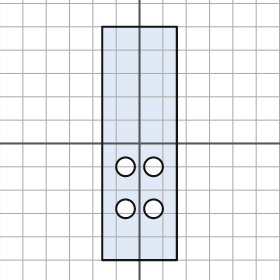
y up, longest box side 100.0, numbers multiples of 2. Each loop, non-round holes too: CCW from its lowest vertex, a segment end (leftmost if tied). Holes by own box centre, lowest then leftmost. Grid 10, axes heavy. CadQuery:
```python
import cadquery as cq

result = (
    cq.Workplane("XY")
    .moveTo(-16.0, -50.0)
    .lineTo(16.0, -50.0)
    .lineTo(16.0, 50.0)
    .lineTo(-16.0, 50.0)
    .close()
    .moveTo(-6.0, -28.0)
    .circle(4.0)
    .moveTo(6.0, -28.0)
    .circle(4.0)
    .moveTo(-6.0, -10.0)
    .circle(4.0)
    .moveTo(6.0, -10.0)
    .circle(4.0)
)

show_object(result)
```